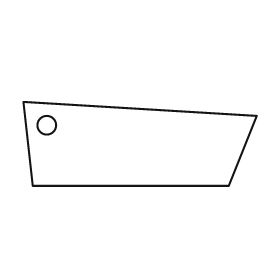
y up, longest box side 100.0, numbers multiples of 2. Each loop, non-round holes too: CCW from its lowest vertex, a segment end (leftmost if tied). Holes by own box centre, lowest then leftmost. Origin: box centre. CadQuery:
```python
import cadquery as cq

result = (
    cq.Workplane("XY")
    .moveTo(-46.0, -18.0)
    .lineTo(38.0, -18.0)
    .lineTo(50.0, 12.0)
    .lineTo(-50.0, 18.0)
    .close()
    .moveTo(-40.0, 8.0)
    .circle(4.0)
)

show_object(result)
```